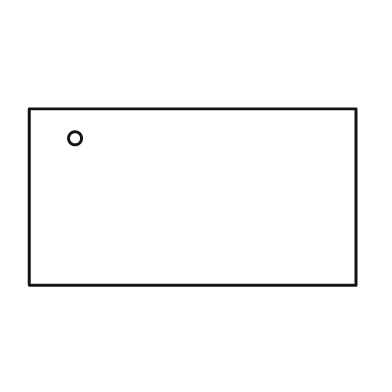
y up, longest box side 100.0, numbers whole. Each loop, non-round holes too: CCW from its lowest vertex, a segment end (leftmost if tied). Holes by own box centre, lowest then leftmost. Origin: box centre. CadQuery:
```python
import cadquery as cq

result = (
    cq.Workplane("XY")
    .moveTo(-50.0, -27.0)
    .lineTo(50.0, -27.0)
    .lineTo(50.0, 27.0)
    .lineTo(-50.0, 27.0)
    .close()
    .moveTo(-36.0, 18.0)
    .circle(2.0)
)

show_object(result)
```